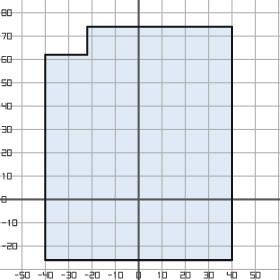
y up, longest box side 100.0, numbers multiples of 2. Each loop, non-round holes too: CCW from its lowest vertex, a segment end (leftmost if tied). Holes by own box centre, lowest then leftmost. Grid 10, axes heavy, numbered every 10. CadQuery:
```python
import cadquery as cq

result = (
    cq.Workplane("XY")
    .moveTo(-40.0, -26.0)
    .lineTo(40.0, -26.0)
    .lineTo(40.0, 74.0)
    .lineTo(-22.0, 74.0)
    .lineTo(-22.0, 62.0)
    .lineTo(-40.0, 62.0)
    .close()
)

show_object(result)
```